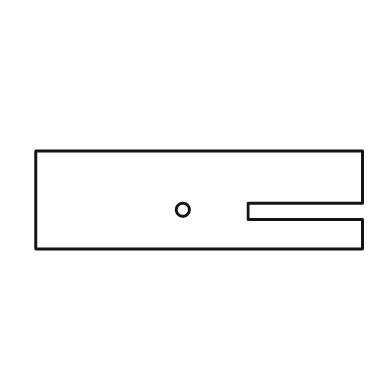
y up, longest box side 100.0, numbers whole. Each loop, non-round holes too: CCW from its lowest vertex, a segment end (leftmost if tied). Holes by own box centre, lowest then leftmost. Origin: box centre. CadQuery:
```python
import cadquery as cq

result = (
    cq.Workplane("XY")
    .moveTo(-50.0, -15.0)
    .lineTo(50.0, -15.0)
    .lineTo(50.0, -6.0)
    .lineTo(15.0, -6.0)
    .lineTo(15.0, -1.0)
    .lineTo(50.0, -1.0)
    .lineTo(50.0, 15.0)
    .lineTo(-50.0, 15.0)
    .close()
    .moveTo(-5.0, -3.0)
    .circle(2.0)
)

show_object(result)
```